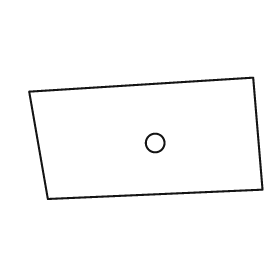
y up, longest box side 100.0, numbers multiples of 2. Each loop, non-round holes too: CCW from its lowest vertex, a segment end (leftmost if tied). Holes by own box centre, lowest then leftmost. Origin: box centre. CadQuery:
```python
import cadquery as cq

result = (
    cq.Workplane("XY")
    .moveTo(-42.0, -26.0)
    .lineTo(50.0, -22.0)
    .lineTo(46.0, 26.0)
    .lineTo(-50.0, 20.0)
    .close()
    .moveTo(4.0, -2.0)
    .circle(4.0)
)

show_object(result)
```